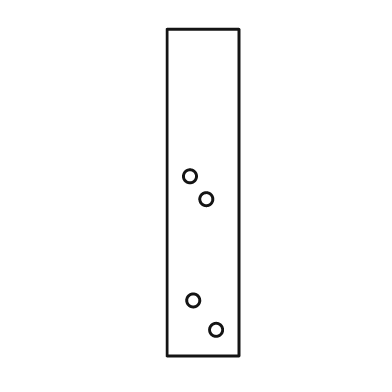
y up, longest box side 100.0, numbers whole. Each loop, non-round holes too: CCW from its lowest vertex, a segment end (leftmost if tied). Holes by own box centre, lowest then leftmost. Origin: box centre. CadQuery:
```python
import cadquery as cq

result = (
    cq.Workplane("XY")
    .moveTo(-11.0, -50.0)
    .lineTo(11.0, -50.0)
    .lineTo(11.0, 50.0)
    .lineTo(-11.0, 50.0)
    .close()
    .moveTo(4.0, -42.0)
    .circle(2.0)
    .moveTo(-3.0, -33.0)
    .circle(2.0)
    .moveTo(1.0, -2.0)
    .circle(2.0)
    .moveTo(-4.0, 5.0)
    .circle(2.0)
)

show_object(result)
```